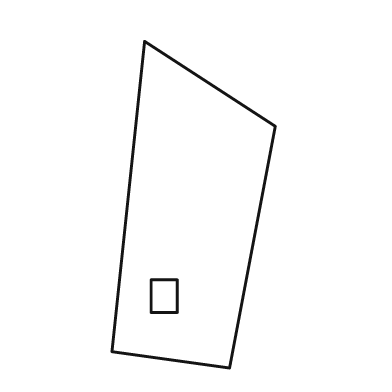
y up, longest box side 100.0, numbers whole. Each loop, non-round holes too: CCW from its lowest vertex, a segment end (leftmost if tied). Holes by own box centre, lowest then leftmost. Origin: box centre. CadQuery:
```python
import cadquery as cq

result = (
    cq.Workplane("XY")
    .moveTo(11.0, -50.0)
    .lineTo(25.0, 24.0)
    .lineTo(-15.0, 50.0)
    .lineTo(-25.0, -45.0)
    .close()
    .moveTo(-13.0, -33.0)
    .lineTo(-5.0, -33.0)
    .lineTo(-5.0, -23.0)
    .lineTo(-13.0, -23.0)
    .close()
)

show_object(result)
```